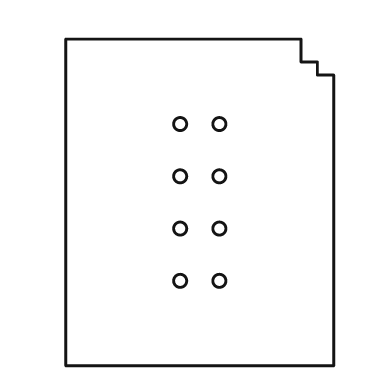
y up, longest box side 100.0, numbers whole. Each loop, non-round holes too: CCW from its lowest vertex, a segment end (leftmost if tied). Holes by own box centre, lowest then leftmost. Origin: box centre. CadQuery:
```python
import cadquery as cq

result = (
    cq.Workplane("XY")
    .moveTo(-41.0, -50.0)
    .lineTo(41.0, -50.0)
    .lineTo(41.0, 39.0)
    .lineTo(36.0, 39.0)
    .lineTo(36.0, 43.0)
    .lineTo(31.0, 43.0)
    .lineTo(31.0, 50.0)
    .lineTo(-41.0, 50.0)
    .close()
    .moveTo(-6.0, -24.0)
    .circle(2.0)
    .moveTo(6.0, -24.0)
    .circle(2.0)
    .moveTo(-6.0, -8.0)
    .circle(2.0)
    .moveTo(6.0, -8.0)
    .circle(2.0)
    .moveTo(-6.0, 8.0)
    .circle(2.0)
    .moveTo(6.0, 8.0)
    .circle(2.0)
    .moveTo(-6.0, 24.0)
    .circle(2.0)
    .moveTo(6.0, 24.0)
    .circle(2.0)
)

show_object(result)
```